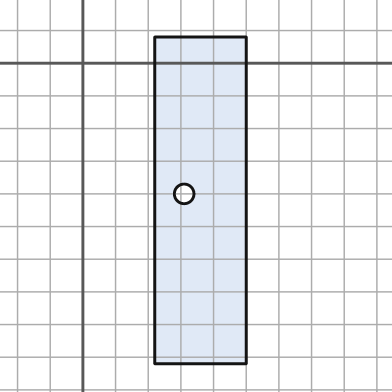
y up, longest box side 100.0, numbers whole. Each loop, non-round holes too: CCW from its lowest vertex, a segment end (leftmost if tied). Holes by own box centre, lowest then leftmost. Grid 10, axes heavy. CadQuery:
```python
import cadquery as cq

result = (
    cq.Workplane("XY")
    .moveTo(22.0, -92.0)
    .lineTo(50.0, -92.0)
    .lineTo(50.0, 8.0)
    .lineTo(22.0, 8.0)
    .close()
    .moveTo(31.0, -40.0)
    .circle(3.0)
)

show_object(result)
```